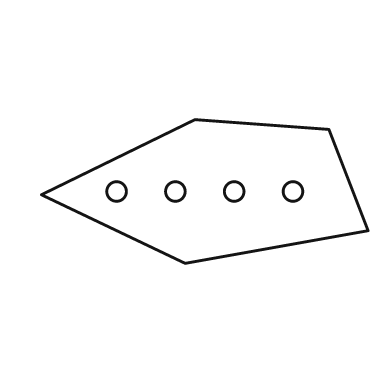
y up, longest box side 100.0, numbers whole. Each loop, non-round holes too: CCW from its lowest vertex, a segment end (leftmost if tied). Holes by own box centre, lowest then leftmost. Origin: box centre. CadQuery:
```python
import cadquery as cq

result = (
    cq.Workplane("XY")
    .moveTo(-6.0, -22.0)
    .lineTo(50.0, -12.0)
    .lineTo(38.0, 19.0)
    .lineTo(-3.0, 22.0)
    .lineTo(-50.0, -1.0)
    .close()
    .moveTo(-27.0, 0.0)
    .circle(3.0)
    .moveTo(-9.0, 0.0)
    .circle(3.0)
    .moveTo(9.0, 0.0)
    .circle(3.0)
    .moveTo(27.0, 0.0)
    .circle(3.0)
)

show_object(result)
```